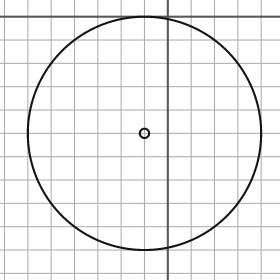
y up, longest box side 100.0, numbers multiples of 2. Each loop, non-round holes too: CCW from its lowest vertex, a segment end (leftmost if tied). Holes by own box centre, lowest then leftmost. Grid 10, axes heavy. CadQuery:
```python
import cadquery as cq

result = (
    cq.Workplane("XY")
    .moveTo(-10.0, -50.0)
    .circle(50.0)
    .moveTo(-10.0, -50.0)
    .circle(2.0)
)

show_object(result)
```